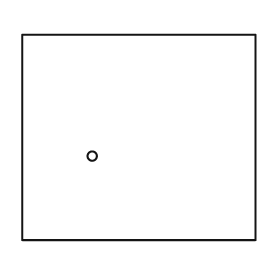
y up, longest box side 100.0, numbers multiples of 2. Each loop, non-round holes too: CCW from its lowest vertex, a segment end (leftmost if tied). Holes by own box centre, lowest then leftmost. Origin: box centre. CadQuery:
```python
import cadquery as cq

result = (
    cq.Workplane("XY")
    .moveTo(-50.0, -44.0)
    .lineTo(50.0, -44.0)
    .lineTo(50.0, 44.0)
    .lineTo(-50.0, 44.0)
    .close()
    .moveTo(-20.0, -8.0)
    .circle(2.0)
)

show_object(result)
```